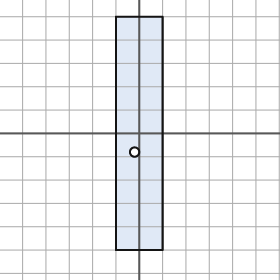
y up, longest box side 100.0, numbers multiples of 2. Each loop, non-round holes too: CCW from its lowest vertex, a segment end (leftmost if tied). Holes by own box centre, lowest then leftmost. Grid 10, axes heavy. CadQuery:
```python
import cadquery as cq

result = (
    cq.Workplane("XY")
    .moveTo(-10.0, -50.0)
    .lineTo(10.0, -50.0)
    .lineTo(10.0, 50.0)
    .lineTo(-10.0, 50.0)
    .close()
    .moveTo(-2.0, -8.0)
    .circle(2.0)
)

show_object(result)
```